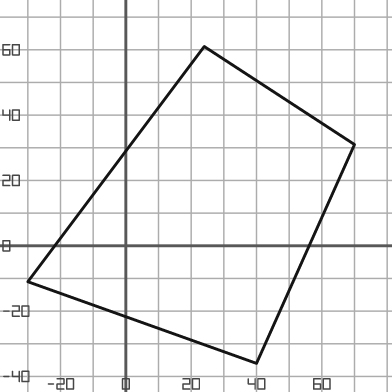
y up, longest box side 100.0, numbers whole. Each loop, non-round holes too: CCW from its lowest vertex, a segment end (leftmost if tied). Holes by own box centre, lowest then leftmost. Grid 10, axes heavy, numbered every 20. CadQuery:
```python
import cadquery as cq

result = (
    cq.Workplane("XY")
    .moveTo(40.0, -36.0)
    .lineTo(70.0, 31.0)
    .lineTo(24.0, 61.0)
    .lineTo(-30.0, -11.0)
    .close()
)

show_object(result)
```